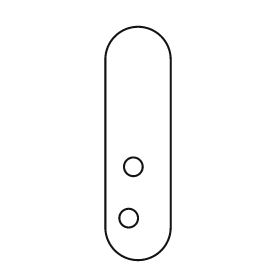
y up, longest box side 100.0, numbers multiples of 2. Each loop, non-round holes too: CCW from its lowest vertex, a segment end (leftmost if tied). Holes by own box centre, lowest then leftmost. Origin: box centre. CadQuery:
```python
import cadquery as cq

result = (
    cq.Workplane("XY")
    .moveTo(-14.0, -36.0)
    .threePointArc((0.0, -50.0), (14.0, -36.0))
    .lineTo(14.0, 36.0)
    .threePointArc((0.0, 50.0), (-14.0, 36.0))
    .close()
    .moveTo(-4.0, -32.0)
    .circle(4.0)
    .moveTo(-2.0, -10.0)
    .circle(4.0)
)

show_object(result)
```